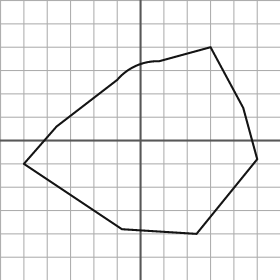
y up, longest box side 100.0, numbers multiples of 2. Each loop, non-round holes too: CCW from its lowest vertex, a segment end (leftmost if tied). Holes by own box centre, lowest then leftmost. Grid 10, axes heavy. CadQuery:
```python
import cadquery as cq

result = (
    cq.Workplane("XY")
    .moveTo(24.0, -40.0)
    .lineTo(50.0, -8.0)
    .lineTo(44.0, 14.0)
    .lineTo(30.0, 40.0)
    .lineTo(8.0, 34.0)
    .threePointArc((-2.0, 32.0), (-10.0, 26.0))
    .lineTo(-36.0, 6.0)
    .lineTo(-50.0, -10.0)
    .lineTo(-8.0, -38.0)
    .close()
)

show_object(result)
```